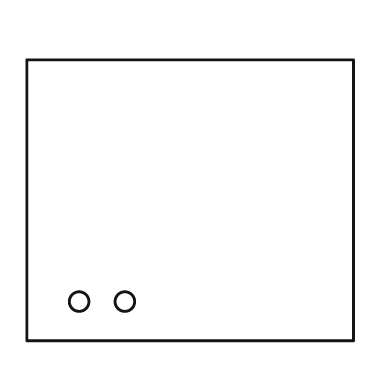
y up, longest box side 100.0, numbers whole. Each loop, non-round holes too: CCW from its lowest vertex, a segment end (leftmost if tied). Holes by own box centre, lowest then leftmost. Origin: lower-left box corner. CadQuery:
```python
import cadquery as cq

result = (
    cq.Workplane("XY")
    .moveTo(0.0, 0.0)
    .lineTo(100.0, 0.0)
    .lineTo(100.0, 86.0)
    .lineTo(0.0, 86.0)
    .close()
    .moveTo(16.0, 12.0)
    .circle(3.0)
    .moveTo(30.0, 12.0)
    .circle(3.0)
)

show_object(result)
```